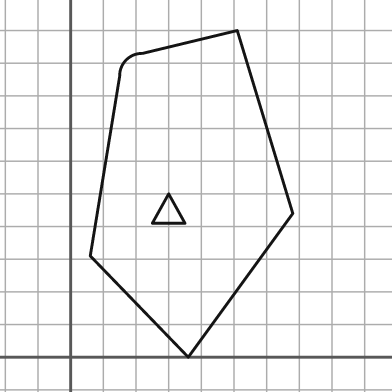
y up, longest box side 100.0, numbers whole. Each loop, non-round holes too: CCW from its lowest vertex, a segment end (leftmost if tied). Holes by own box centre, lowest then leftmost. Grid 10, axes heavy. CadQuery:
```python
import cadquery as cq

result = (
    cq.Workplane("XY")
    .moveTo(36.0, 0.0)
    .lineTo(68.0, 44.0)
    .lineTo(51.0, 100.0)
    .lineTo(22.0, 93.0)
    .threePointArc((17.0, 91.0), (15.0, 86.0))
    .lineTo(6.0, 31.0)
    .close()
    .moveTo(25.0, 41.0)
    .lineTo(35.0, 41.0)
    .lineTo(30.0, 50.0)
    .close()
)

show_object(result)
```